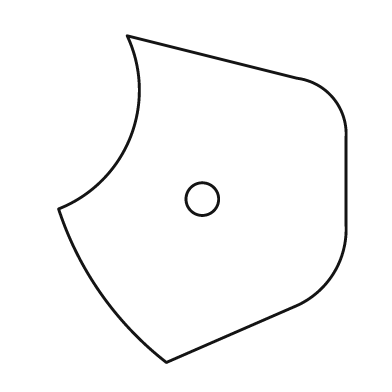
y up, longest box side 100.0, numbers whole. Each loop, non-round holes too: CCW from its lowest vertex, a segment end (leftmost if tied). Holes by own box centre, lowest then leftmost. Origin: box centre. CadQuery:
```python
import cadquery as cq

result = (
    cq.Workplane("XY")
    .moveTo(-11.0, -50.0)
    .lineTo(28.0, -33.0)
    .threePointArc((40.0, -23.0), (44.0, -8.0))
    .lineTo(44.0, 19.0)
    .threePointArc((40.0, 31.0), (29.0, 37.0))
    .lineTo(-23.0, 50.0)
    .threePointArc((-22.0, 19.0), (-44.0, -3.0))
    .threePointArc((-31.0, -29.0), (-11.0, -50.0))
    .close()
    .moveTo(0.0, 0.0)
    .circle(5.0)
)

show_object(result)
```